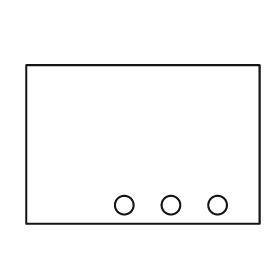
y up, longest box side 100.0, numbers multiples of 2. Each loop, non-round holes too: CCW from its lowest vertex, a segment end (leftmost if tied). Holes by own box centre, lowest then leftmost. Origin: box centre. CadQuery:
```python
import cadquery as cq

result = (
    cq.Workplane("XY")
    .moveTo(-50.0, -34.0)
    .lineTo(50.0, -34.0)
    .lineTo(50.0, 34.0)
    .lineTo(-50.0, 34.0)
    .close()
    .moveTo(-8.0, -26.0)
    .circle(4.0)
    .moveTo(12.0, -26.0)
    .circle(4.0)
    .moveTo(32.0, -26.0)
    .circle(4.0)
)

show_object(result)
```